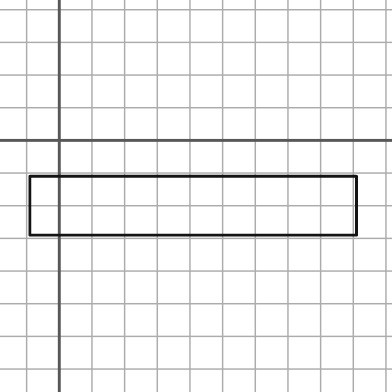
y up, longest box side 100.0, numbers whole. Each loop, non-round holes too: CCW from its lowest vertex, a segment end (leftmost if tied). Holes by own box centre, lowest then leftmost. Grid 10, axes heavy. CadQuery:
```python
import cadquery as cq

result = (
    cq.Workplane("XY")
    .moveTo(-9.0, -29.0)
    .lineTo(91.0, -29.0)
    .lineTo(91.0, -11.0)
    .lineTo(-9.0, -11.0)
    .close()
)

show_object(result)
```